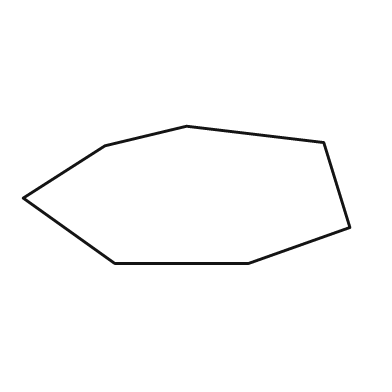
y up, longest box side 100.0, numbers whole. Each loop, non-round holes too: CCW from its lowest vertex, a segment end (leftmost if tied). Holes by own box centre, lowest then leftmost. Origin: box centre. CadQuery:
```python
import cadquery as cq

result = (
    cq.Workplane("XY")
    .moveTo(-22.0, -21.0)
    .lineTo(19.0, -21.0)
    .lineTo(50.0, -10.0)
    .lineTo(42.0, 16.0)
    .lineTo(0.0, 21.0)
    .lineTo(-25.0, 15.0)
    .lineTo(-50.0, -1.0)
    .close()
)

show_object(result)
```